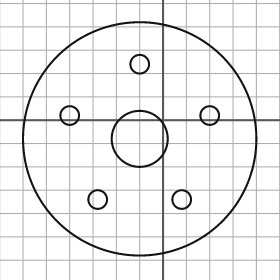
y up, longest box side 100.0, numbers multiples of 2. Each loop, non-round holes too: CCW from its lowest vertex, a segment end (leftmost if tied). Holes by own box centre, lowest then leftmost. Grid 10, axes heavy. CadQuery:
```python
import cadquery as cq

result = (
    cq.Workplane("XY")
    .moveTo(-10.0, -8.0)
    .circle(50.0)
    .moveTo(-28.0, -34.0)
    .circle(4.0)
    .moveTo(8.0, -34.0)
    .circle(4.0)
    .moveTo(-10.0, -8.0)
    .circle(12.0)
    .moveTo(-40.0, 2.0)
    .circle(4.0)
    .moveTo(20.0, 2.0)
    .circle(4.0)
    .moveTo(-10.0, 24.0)
    .circle(4.0)
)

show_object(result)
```